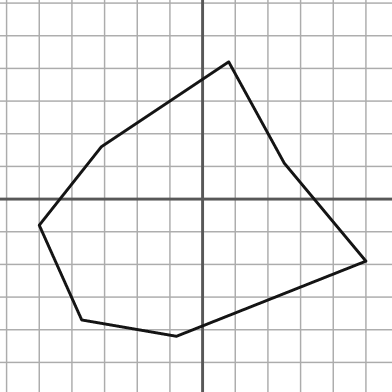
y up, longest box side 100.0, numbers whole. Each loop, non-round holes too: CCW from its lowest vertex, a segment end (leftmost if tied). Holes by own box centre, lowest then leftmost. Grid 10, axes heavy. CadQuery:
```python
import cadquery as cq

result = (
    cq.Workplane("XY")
    .moveTo(-8.0, -42.0)
    .lineTo(50.0, -19.0)
    .lineTo(25.0, 11.0)
    .lineTo(8.0, 42.0)
    .lineTo(-31.0, 16.0)
    .lineTo(-50.0, -8.0)
    .lineTo(-37.0, -37.0)
    .close()
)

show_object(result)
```